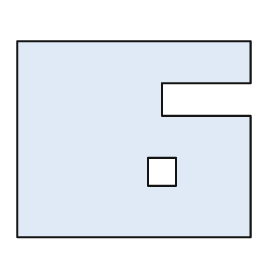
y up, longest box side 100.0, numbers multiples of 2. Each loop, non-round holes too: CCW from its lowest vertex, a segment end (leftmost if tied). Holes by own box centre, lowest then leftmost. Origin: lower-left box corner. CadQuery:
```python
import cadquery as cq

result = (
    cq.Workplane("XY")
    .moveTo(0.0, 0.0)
    .lineTo(100.0, 0.0)
    .lineTo(100.0, 52.0)
    .lineTo(62.0, 52.0)
    .lineTo(62.0, 66.0)
    .lineTo(100.0, 66.0)
    .lineTo(100.0, 84.0)
    .lineTo(0.0, 84.0)
    .close()
    .moveTo(56.0, 22.0)
    .lineTo(68.0, 22.0)
    .lineTo(68.0, 34.0)
    .lineTo(56.0, 34.0)
    .close()
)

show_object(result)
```